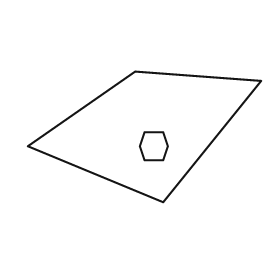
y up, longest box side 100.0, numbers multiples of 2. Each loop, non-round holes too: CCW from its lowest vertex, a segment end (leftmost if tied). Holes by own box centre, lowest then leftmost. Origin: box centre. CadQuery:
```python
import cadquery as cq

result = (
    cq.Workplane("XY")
    .moveTo(8.0, -28.0)
    .lineTo(50.0, 24.0)
    .lineTo(-4.0, 28.0)
    .lineTo(-50.0, -4.0)
    .close()
    .moveTo(0.0, -10.0)
    .lineTo(8.0, -10.0)
    .lineTo(10.0, -4.0)
    .lineTo(8.0, 2.0)
    .lineTo(0.0, 2.0)
    .lineTo(-2.0, -4.0)
    .close()
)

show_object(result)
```